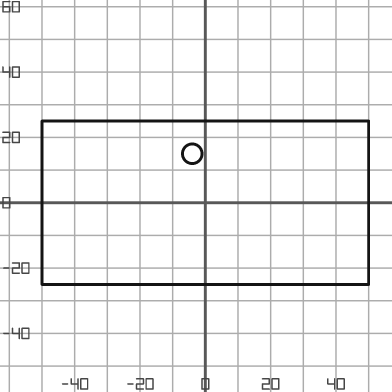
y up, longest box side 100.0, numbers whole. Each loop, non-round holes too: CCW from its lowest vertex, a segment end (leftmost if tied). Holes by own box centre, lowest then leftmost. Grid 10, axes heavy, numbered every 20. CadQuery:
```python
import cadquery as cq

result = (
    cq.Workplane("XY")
    .moveTo(-50.0, -25.0)
    .lineTo(50.0, -25.0)
    .lineTo(50.0, 25.0)
    .lineTo(-50.0, 25.0)
    .close()
    .moveTo(-4.0, 15.0)
    .circle(3.0)
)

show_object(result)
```